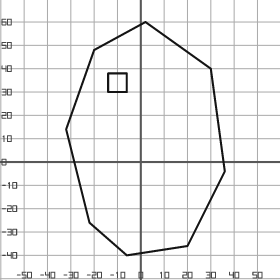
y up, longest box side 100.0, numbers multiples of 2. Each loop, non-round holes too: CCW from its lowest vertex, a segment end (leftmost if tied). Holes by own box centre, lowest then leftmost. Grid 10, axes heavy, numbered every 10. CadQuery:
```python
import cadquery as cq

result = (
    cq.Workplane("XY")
    .moveTo(-6.0, -40.0)
    .lineTo(20.0, -36.0)
    .lineTo(36.0, -4.0)
    .lineTo(30.0, 40.0)
    .lineTo(2.0, 60.0)
    .lineTo(-20.0, 48.0)
    .lineTo(-32.0, 14.0)
    .lineTo(-22.0, -26.0)
    .close()
    .moveTo(-14.0, 30.0)
    .lineTo(-6.0, 30.0)
    .lineTo(-6.0, 38.0)
    .lineTo(-14.0, 38.0)
    .close()
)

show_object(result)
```